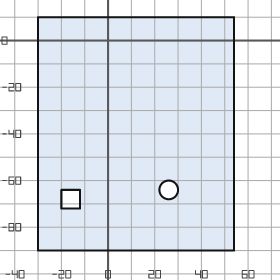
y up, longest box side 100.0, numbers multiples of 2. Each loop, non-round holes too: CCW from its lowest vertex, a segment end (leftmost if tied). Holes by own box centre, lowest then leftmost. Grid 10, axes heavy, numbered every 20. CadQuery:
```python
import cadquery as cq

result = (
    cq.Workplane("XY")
    .moveTo(-30.0, -90.0)
    .lineTo(54.0, -90.0)
    .lineTo(54.0, 10.0)
    .lineTo(-30.0, 10.0)
    .close()
    .moveTo(-20.0, -72.0)
    .lineTo(-12.0, -72.0)
    .lineTo(-12.0, -64.0)
    .lineTo(-20.0, -64.0)
    .close()
    .moveTo(26.0, -64.0)
    .circle(4.0)
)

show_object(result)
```